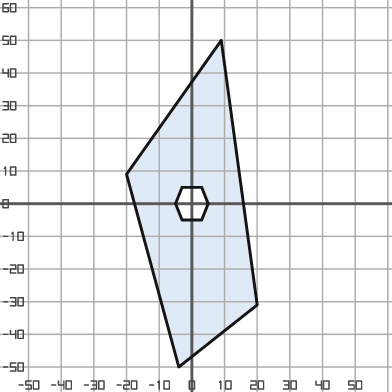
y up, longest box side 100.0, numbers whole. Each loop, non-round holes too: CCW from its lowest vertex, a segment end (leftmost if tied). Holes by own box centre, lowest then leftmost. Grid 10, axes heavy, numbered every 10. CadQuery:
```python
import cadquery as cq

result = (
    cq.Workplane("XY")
    .moveTo(-4.0, -50.0)
    .lineTo(20.0, -31.0)
    .lineTo(9.0, 50.0)
    .lineTo(-20.0, 9.0)
    .close()
    .moveTo(-3.0, -5.0)
    .lineTo(3.0, -5.0)
    .lineTo(5.0, 0.0)
    .lineTo(3.0, 5.0)
    .lineTo(-3.0, 5.0)
    .lineTo(-5.0, 0.0)
    .close()
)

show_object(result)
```